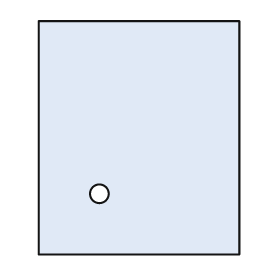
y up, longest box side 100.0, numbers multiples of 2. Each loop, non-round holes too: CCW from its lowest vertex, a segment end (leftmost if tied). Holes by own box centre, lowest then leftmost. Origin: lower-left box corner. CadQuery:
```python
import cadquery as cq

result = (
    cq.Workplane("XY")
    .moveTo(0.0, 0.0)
    .lineTo(86.0, 0.0)
    .lineTo(86.0, 100.0)
    .lineTo(0.0, 100.0)
    .close()
    .moveTo(26.0, 26.0)
    .circle(4.0)
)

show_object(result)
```